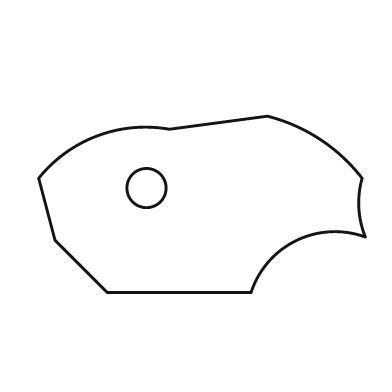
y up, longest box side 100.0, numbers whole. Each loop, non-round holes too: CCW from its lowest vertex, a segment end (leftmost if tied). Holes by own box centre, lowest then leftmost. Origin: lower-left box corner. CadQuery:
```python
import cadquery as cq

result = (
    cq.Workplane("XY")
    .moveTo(21.0, 0.0)
    .lineTo(65.0, 0.0)
    .threePointArc((79.0, 16.0), (100.0, 17.0))
    .threePointArc((98.0, 26.0), (99.0, 35.0))
    .threePointArc((86.0, 47.0), (70.0, 54.0))
    .lineTo(40.0, 50.0)
    .threePointArc((18.0, 48.0), (0.0, 35.0))
    .lineTo(5.0, 16.0)
    .close()
    .moveTo(33.0, 32.0)
    .circle(6.0)
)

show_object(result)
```